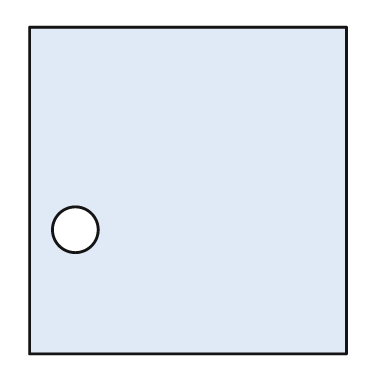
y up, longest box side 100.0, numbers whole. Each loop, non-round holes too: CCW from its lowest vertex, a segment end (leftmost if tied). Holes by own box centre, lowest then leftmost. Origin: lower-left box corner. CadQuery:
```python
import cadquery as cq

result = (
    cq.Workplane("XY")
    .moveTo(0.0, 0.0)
    .lineTo(97.0, 0.0)
    .lineTo(97.0, 100.0)
    .lineTo(0.0, 100.0)
    .close()
    .moveTo(14.0, 38.0)
    .circle(7.0)
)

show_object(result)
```